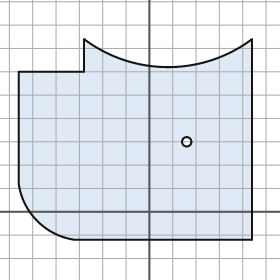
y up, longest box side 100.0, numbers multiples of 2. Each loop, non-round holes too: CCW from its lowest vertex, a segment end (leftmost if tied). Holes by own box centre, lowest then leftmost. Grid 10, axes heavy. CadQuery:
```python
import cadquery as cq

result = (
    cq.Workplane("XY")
    .moveTo(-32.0, -12.0)
    .lineTo(44.0, -12.0)
    .lineTo(44.0, 74.0)
    .threePointArc((8.0, 62.0), (-28.0, 74.0))
    .lineTo(-28.0, 60.0)
    .lineTo(-56.0, 60.0)
    .lineTo(-56.0, 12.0)
    .threePointArc((-48.0, -4.0), (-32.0, -12.0))
    .close()
    .moveTo(16.0, 30.0)
    .circle(2.0)
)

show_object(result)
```